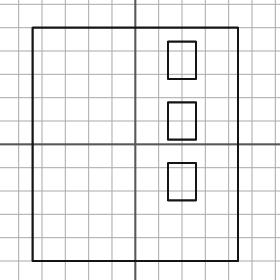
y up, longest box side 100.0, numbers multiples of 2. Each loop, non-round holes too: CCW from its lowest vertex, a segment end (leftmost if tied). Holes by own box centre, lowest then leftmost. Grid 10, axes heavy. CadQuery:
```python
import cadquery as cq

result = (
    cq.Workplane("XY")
    .moveTo(-44.0, -50.0)
    .lineTo(44.0, -50.0)
    .lineTo(44.0, 50.0)
    .lineTo(-44.0, 50.0)
    .close()
    .moveTo(14.0, -24.0)
    .lineTo(26.0, -24.0)
    .lineTo(26.0, -8.0)
    .lineTo(14.0, -8.0)
    .close()
    .moveTo(14.0, 2.0)
    .lineTo(26.0, 2.0)
    .lineTo(26.0, 18.0)
    .lineTo(14.0, 18.0)
    .close()
    .moveTo(14.0, 28.0)
    .lineTo(26.0, 28.0)
    .lineTo(26.0, 44.0)
    .lineTo(14.0, 44.0)
    .close()
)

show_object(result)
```